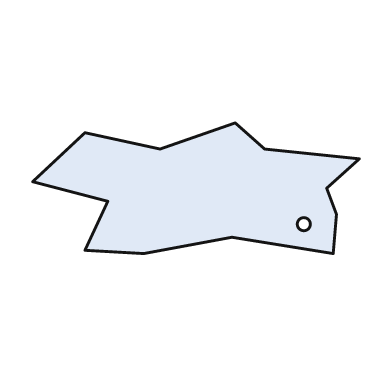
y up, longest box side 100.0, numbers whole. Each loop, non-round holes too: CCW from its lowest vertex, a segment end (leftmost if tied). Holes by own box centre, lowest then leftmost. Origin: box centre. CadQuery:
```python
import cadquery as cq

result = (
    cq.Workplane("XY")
    .moveTo(-16.0, -20.0)
    .lineTo(11.0, -15.0)
    .lineTo(42.0, -20.0)
    .lineTo(43.0, -8.0)
    .lineTo(40.0, 0.0)
    .lineTo(50.0, 9.0)
    .lineTo(21.0, 12.0)
    .lineTo(12.0, 20.0)
    .lineTo(-11.0, 12.0)
    .lineTo(-34.0, 17.0)
    .lineTo(-50.0, 2.0)
    .lineTo(-27.0, -4.0)
    .lineTo(-34.0, -19.0)
    .close()
    .moveTo(33.0, -11.0)
    .circle(2.0)
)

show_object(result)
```